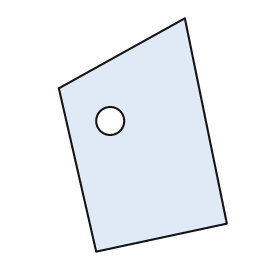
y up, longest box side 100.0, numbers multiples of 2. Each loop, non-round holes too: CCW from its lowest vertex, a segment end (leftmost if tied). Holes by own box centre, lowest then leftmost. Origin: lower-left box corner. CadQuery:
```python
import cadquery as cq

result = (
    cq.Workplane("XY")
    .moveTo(16.0, 0.0)
    .lineTo(72.0, 12.0)
    .lineTo(54.0, 100.0)
    .lineTo(0.0, 70.0)
    .close()
    .moveTo(22.0, 56.0)
    .circle(6.0)
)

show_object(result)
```